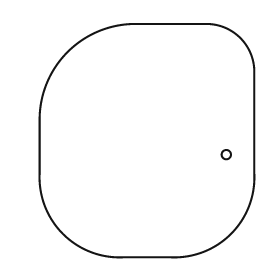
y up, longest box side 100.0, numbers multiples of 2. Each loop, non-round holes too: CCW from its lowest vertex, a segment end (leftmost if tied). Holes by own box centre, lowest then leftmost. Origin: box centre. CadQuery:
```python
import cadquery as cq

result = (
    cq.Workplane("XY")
    .moveTo(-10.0, -50.0)
    .lineTo(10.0, -50.0)
    .threePointArc((36.0, -40.0), (46.0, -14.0))
    .lineTo(46.0, 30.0)
    .threePointArc((40.0, 44.0), (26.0, 50.0))
    .lineTo(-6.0, 50.0)
    .threePointArc((-34.0, 38.0), (-46.0, 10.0))
    .lineTo(-46.0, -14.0)
    .threePointArc((-36.0, -40.0), (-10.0, -50.0))
    .close()
    .moveTo(34.0, -6.0)
    .circle(2.0)
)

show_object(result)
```